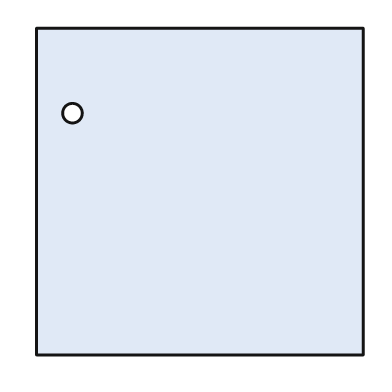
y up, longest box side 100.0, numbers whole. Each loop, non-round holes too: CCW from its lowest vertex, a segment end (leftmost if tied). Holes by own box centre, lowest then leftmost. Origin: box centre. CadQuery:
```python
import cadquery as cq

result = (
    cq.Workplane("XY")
    .moveTo(-50.0, -50.0)
    .lineTo(50.0, -50.0)
    .lineTo(50.0, 50.0)
    .lineTo(-50.0, 50.0)
    .close()
    .moveTo(-39.0, 24.0)
    .circle(3.0)
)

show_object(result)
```